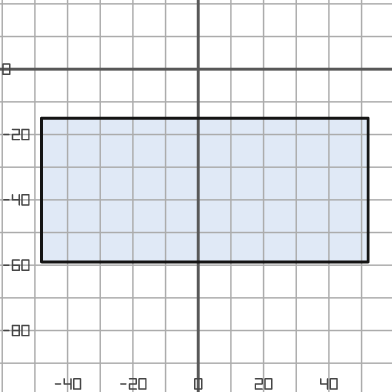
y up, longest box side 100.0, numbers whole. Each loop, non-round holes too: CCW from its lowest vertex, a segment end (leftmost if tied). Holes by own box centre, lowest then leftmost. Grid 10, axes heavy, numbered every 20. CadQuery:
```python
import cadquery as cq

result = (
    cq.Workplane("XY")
    .moveTo(-48.0, -59.0)
    .lineTo(52.0, -59.0)
    .lineTo(52.0, -15.0)
    .lineTo(-48.0, -15.0)
    .close()
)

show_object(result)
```